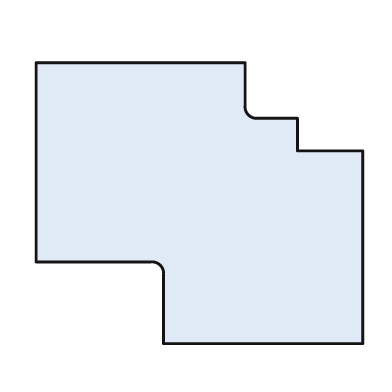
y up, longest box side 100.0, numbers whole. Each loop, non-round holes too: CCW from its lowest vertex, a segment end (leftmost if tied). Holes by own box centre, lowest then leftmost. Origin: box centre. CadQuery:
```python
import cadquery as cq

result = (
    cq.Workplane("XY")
    .moveTo(-11.0, -43.0)
    .lineTo(50.0, -43.0)
    .lineTo(50.0, 16.0)
    .lineTo(30.0, 16.0)
    .lineTo(30.0, 26.0)
    .lineTo(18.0, 26.0)
    .threePointArc((15.0, 27.0), (14.0, 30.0))
    .lineTo(14.0, 43.0)
    .lineTo(-50.0, 43.0)
    .lineTo(-50.0, -18.0)
    .lineTo(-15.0, -18.0)
    .threePointArc((-12.0, -19.0), (-11.0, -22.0))
    .close()
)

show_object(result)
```